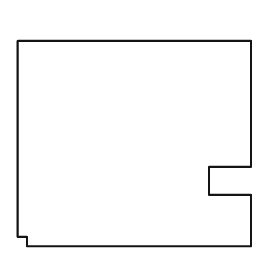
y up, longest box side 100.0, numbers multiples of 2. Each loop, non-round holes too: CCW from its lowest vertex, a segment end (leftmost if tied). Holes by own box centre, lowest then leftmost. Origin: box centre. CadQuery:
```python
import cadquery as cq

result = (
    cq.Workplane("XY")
    .moveTo(-46.0, -44.0)
    .lineTo(50.0, -44.0)
    .lineTo(50.0, -22.0)
    .lineTo(32.0, -22.0)
    .lineTo(32.0, -10.0)
    .lineTo(50.0, -10.0)
    .lineTo(50.0, 44.0)
    .lineTo(-50.0, 44.0)
    .lineTo(-50.0, -40.0)
    .lineTo(-46.0, -40.0)
    .close()
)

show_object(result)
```